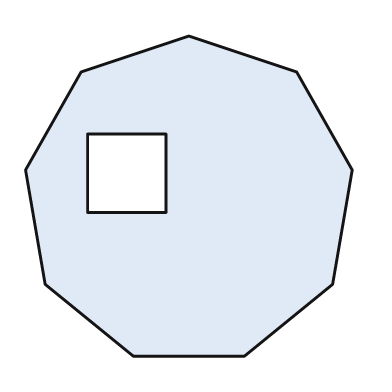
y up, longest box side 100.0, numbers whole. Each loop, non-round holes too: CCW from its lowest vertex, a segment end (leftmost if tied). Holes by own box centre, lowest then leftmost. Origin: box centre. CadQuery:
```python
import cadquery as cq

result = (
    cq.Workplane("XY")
    .moveTo(-17.0, -49.0)
    .lineTo(17.0, -49.0)
    .lineTo(44.0, -27.0)
    .lineTo(50.0, 8.0)
    .lineTo(33.0, 38.0)
    .lineTo(0.0, 49.0)
    .lineTo(-33.0, 38.0)
    .lineTo(-50.0, 8.0)
    .lineTo(-44.0, -27.0)
    .close()
    .moveTo(-31.0, -5.0)
    .lineTo(-7.0, -5.0)
    .lineTo(-7.0, 19.0)
    .lineTo(-31.0, 19.0)
    .close()
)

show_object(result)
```